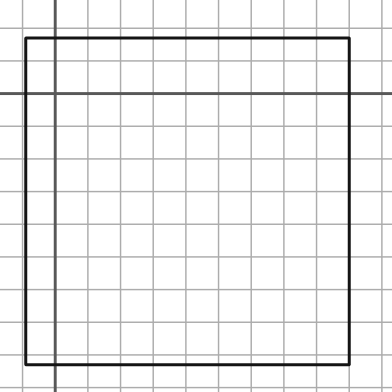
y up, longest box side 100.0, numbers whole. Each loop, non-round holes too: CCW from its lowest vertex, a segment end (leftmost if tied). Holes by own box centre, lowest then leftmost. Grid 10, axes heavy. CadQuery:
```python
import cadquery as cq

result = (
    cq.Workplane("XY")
    .moveTo(-9.0, -83.0)
    .lineTo(90.0, -83.0)
    .lineTo(90.0, 17.0)
    .lineTo(-9.0, 17.0)
    .close()
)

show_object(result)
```